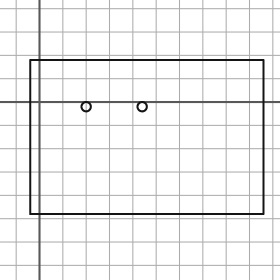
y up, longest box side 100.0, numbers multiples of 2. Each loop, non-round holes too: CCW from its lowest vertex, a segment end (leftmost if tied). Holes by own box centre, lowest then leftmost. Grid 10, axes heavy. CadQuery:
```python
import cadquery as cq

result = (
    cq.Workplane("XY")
    .moveTo(-4.0, -48.0)
    .lineTo(96.0, -48.0)
    .lineTo(96.0, 18.0)
    .lineTo(-4.0, 18.0)
    .close()
    .moveTo(20.0, -2.0)
    .circle(2.0)
    .moveTo(44.0, -2.0)
    .circle(2.0)
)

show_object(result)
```